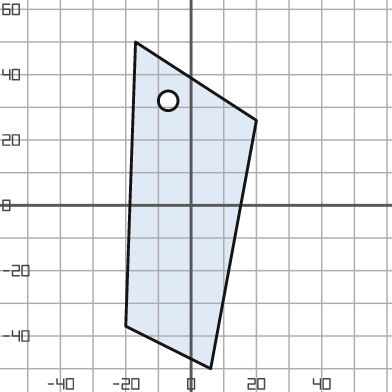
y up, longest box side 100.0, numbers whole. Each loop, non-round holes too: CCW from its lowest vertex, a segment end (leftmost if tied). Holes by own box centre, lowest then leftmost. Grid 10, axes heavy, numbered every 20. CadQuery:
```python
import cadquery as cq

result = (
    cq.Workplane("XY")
    .moveTo(6.0, -50.0)
    .lineTo(20.0, 26.0)
    .lineTo(-17.0, 50.0)
    .lineTo(-20.0, -37.0)
    .close()
    .moveTo(-7.0, 32.0)
    .circle(3.0)
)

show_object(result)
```